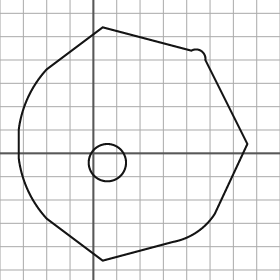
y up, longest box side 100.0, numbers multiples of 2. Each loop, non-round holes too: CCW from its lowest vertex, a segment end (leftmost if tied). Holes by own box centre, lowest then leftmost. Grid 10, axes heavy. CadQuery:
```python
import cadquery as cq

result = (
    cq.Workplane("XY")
    .moveTo(4.0, -46.0)
    .lineTo(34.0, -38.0)
    .threePointArc((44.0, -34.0), (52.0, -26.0))
    .lineTo(66.0, 4.0)
    .lineTo(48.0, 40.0)
    .threePointArc((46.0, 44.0), (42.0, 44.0))
    .lineTo(4.0, 54.0)
    .lineTo(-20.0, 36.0)
    .threePointArc((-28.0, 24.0), (-32.0, 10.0))
    .lineTo(-32.0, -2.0)
    .threePointArc((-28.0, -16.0), (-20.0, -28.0))
    .close()
    .moveTo(6.0, -4.0)
    .circle(8.0)
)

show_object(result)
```